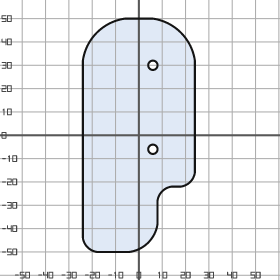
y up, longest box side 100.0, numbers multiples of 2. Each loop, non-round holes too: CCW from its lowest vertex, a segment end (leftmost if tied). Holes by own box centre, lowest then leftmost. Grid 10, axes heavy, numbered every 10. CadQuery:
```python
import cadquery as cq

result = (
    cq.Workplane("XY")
    .moveTo(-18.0, -50.0)
    .lineTo(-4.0, -50.0)
    .threePointArc((4.0, -46.0), (8.0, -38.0))
    .lineTo(8.0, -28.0)
    .threePointArc((10.0, -24.0), (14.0, -22.0))
    .lineTo(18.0, -22.0)
    .threePointArc((22.0, -20.0), (24.0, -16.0))
    .lineTo(24.0, 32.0)
    .threePointArc((18.0, 44.0), (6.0, 50.0))
    .lineTo(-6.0, 50.0)
    .threePointArc((-18.0, 44.0), (-24.0, 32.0))
    .lineTo(-24.0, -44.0)
    .threePointArc((-22.0, -48.0), (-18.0, -50.0))
    .close()
    .moveTo(6.0, -6.0)
    .circle(2.0)
    .moveTo(6.0, 30.0)
    .circle(2.0)
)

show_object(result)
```